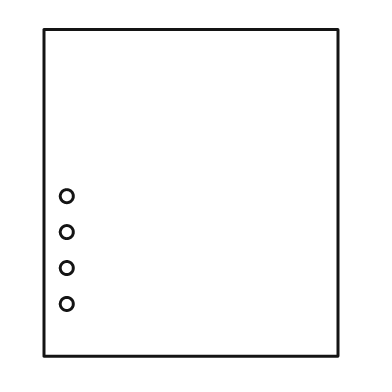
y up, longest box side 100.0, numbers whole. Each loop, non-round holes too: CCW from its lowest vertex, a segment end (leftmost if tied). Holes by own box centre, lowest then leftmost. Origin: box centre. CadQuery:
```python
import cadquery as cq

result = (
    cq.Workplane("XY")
    .moveTo(-45.0, -50.0)
    .lineTo(45.0, -50.0)
    .lineTo(45.0, 50.0)
    .lineTo(-45.0, 50.0)
    .close()
    .moveTo(-38.0, -34.0)
    .circle(2.0)
    .moveTo(-38.0, -23.0)
    .circle(2.0)
    .moveTo(-38.0, -12.0)
    .circle(2.0)
    .moveTo(-38.0, -1.0)
    .circle(2.0)
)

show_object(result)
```